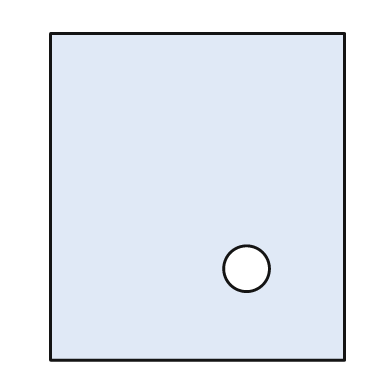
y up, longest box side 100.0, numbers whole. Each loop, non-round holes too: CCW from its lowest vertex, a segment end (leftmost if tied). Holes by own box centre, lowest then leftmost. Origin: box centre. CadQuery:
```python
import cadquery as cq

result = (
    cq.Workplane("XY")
    .moveTo(-45.0, -50.0)
    .lineTo(45.0, -50.0)
    .lineTo(45.0, 50.0)
    .lineTo(-45.0, 50.0)
    .close()
    .moveTo(15.0, -22.0)
    .circle(7.0)
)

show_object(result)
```